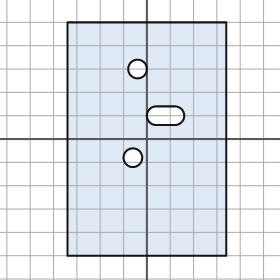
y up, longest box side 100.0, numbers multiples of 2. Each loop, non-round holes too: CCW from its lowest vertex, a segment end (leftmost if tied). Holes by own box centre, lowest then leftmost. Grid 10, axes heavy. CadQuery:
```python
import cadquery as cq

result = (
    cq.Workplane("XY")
    .moveTo(-34.0, -50.0)
    .lineTo(34.0, -50.0)
    .lineTo(34.0, 50.0)
    .lineTo(-34.0, 50.0)
    .close()
    .moveTo(-6.0, -8.0)
    .circle(4.0)
    .moveTo(4.0, 6.0)
    .lineTo(12.0, 6.0)
    .threePointArc((16.0, 10.0), (12.0, 14.0))
    .lineTo(4.0, 14.0)
    .threePointArc((0.0, 10.0), (4.0, 6.0))
    .close()
    .moveTo(-4.0, 30.0)
    .circle(4.0)
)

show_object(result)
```